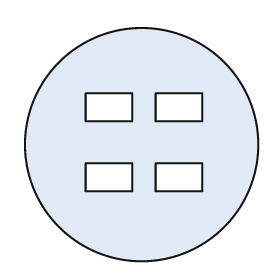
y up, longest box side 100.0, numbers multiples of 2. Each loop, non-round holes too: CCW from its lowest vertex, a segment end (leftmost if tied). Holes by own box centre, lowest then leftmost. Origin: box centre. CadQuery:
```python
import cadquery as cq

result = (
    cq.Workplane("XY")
    .moveTo(0.0, 0.0)
    .circle(50.0)
    .moveTo(-24.0, -20.0)
    .lineTo(-4.0, -20.0)
    .lineTo(-4.0, -8.0)
    .lineTo(-24.0, -8.0)
    .close()
    .moveTo(6.0, -20.0)
    .lineTo(26.0, -20.0)
    .lineTo(26.0, -8.0)
    .lineTo(6.0, -8.0)
    .close()
    .moveTo(-24.0, 10.0)
    .lineTo(-4.0, 10.0)
    .lineTo(-4.0, 22.0)
    .lineTo(-24.0, 22.0)
    .close()
    .moveTo(6.0, 10.0)
    .lineTo(26.0, 10.0)
    .lineTo(26.0, 22.0)
    .lineTo(6.0, 22.0)
    .close()
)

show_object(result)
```